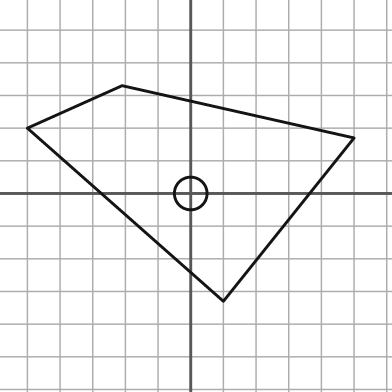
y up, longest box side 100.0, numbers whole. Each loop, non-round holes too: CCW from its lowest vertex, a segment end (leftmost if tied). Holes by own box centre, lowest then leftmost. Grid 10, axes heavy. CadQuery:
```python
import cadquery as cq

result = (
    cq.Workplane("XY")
    .moveTo(10.0, -33.0)
    .lineTo(50.0, 17.0)
    .lineTo(-21.0, 33.0)
    .lineTo(-50.0, 20.0)
    .close()
    .moveTo(0.0, 0.0)
    .circle(5.0)
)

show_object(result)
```